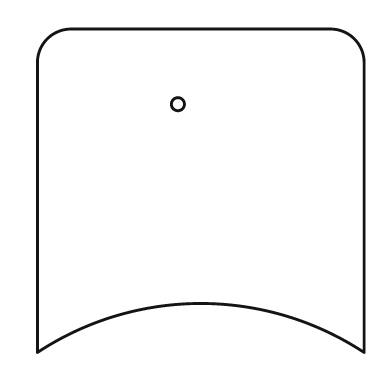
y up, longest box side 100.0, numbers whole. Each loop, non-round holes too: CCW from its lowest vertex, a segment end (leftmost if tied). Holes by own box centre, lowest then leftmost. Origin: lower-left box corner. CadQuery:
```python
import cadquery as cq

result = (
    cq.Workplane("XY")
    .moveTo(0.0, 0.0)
    .threePointArc((50.0, 15.0), (100.0, 0.0))
    .lineTo(100.0, 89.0)
    .threePointArc((97.0, 96.0), (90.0, 99.0))
    .lineTo(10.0, 99.0)
    .threePointArc((3.0, 96.0), (0.0, 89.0))
    .close()
    .moveTo(43.0, 76.0)
    .circle(2.0)
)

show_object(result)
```